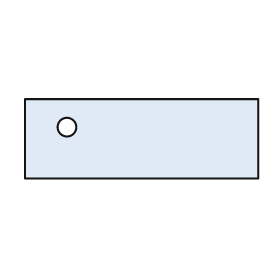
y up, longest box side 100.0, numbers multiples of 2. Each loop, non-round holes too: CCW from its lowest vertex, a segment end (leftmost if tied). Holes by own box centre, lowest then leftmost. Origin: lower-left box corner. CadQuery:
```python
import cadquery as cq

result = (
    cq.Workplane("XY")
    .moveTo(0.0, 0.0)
    .lineTo(100.0, 0.0)
    .lineTo(100.0, 34.0)
    .lineTo(0.0, 34.0)
    .close()
    .moveTo(18.0, 22.0)
    .circle(4.0)
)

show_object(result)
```